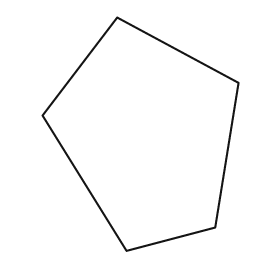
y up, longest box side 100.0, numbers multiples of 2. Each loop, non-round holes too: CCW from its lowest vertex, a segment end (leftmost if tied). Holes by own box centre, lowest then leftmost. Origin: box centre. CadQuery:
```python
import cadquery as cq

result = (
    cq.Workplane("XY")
    .moveTo(-6.0, -50.0)
    .lineTo(32.0, -40.0)
    .lineTo(42.0, 22.0)
    .lineTo(-10.0, 50.0)
    .lineTo(-42.0, 8.0)
    .close()
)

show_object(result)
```